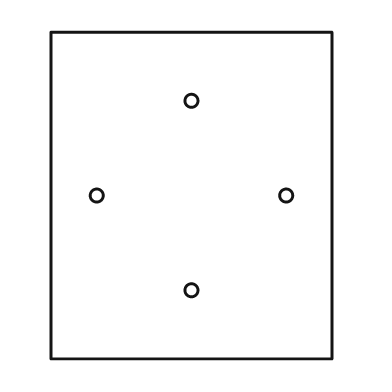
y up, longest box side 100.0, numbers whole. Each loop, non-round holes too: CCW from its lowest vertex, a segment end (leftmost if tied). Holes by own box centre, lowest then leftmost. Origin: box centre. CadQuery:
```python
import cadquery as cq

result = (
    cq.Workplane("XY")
    .moveTo(-43.0, -50.0)
    .lineTo(43.0, -50.0)
    .lineTo(43.0, 50.0)
    .lineTo(-43.0, 50.0)
    .close()
    .moveTo(0.0, -29.0)
    .circle(2.0)
    .moveTo(-29.0, 0.0)
    .circle(2.0)
    .moveTo(29.0, 0.0)
    .circle(2.0)
    .moveTo(0.0, 29.0)
    .circle(2.0)
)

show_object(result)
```